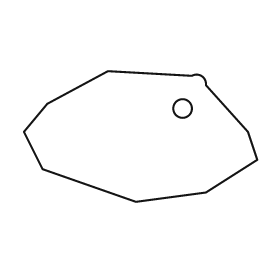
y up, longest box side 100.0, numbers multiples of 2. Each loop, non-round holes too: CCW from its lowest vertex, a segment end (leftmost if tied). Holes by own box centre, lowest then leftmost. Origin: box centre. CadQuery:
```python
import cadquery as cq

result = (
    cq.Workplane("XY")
    .moveTo(-2.0, -28.0)
    .lineTo(28.0, -24.0)
    .lineTo(50.0, -10.0)
    .lineTo(46.0, 2.0)
    .lineTo(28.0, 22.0)
    .threePointArc((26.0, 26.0), (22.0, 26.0))
    .lineTo(-14.0, 28.0)
    .lineTo(-40.0, 14.0)
    .lineTo(-50.0, 2.0)
    .lineTo(-42.0, -14.0)
    .close()
    .moveTo(18.0, 12.0)
    .circle(4.0)
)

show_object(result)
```